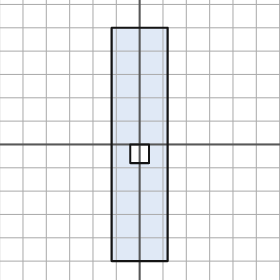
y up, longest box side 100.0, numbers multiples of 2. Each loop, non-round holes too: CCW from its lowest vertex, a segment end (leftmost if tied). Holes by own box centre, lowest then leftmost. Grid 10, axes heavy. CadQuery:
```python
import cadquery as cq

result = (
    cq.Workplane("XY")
    .moveTo(-12.0, -50.0)
    .lineTo(12.0, -50.0)
    .lineTo(12.0, 50.0)
    .lineTo(-12.0, 50.0)
    .close()
    .moveTo(-4.0, -8.0)
    .lineTo(4.0, -8.0)
    .lineTo(4.0, 0.0)
    .lineTo(-4.0, 0.0)
    .close()
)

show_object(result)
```